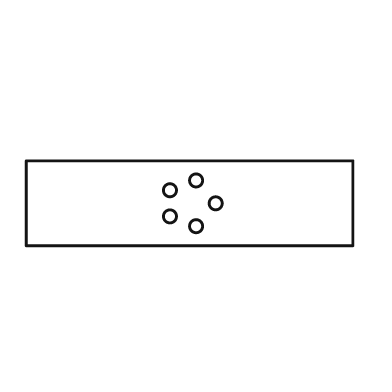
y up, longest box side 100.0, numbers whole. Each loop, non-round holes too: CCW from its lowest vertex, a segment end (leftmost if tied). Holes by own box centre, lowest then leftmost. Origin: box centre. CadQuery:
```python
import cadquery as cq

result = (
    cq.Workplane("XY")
    .moveTo(-50.0, -13.0)
    .lineTo(50.0, -13.0)
    .lineTo(50.0, 13.0)
    .lineTo(-50.0, 13.0)
    .close()
    .moveTo(2.0, -7.0)
    .circle(2.0)
    .moveTo(-6.0, -4.0)
    .circle(2.0)
    .moveTo(8.0, 0.0)
    .circle(2.0)
    .moveTo(-6.0, 4.0)
    .circle(2.0)
    .moveTo(2.0, 7.0)
    .circle(2.0)
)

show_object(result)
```